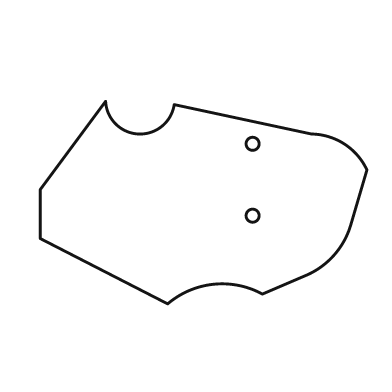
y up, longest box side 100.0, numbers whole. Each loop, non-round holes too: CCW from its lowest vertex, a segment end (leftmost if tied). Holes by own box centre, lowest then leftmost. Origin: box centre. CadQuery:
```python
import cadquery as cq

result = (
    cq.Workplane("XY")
    .moveTo(-11.0, -31.0)
    .threePointArc((3.0, -25.0), (18.0, -28.0))
    .lineTo(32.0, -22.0)
    .threePointArc((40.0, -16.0), (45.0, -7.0))
    .lineTo(50.0, 10.0)
    .threePointArc((43.0, 18.0), (33.0, 21.0))
    .lineTo(-9.0, 30.0)
    .threePointArc((-20.0, 21.0), (-30.0, 31.0))
    .lineTo(-50.0, 4.0)
    .lineTo(-50.0, -11.0)
    .close()
    .moveTo(15.0, -4.0)
    .circle(2.0)
    .moveTo(15.0, 18.0)
    .circle(2.0)
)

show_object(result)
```